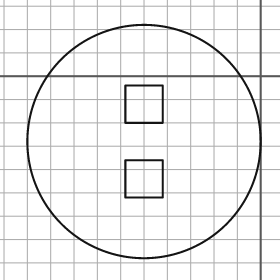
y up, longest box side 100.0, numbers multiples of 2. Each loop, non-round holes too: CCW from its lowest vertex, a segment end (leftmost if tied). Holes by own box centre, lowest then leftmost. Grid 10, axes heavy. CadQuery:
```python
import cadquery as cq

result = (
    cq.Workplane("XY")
    .moveTo(-50.0, -28.0)
    .circle(50.0)
    .moveTo(-58.0, -52.0)
    .lineTo(-42.0, -52.0)
    .lineTo(-42.0, -36.0)
    .lineTo(-58.0, -36.0)
    .close()
    .moveTo(-58.0, -20.0)
    .lineTo(-42.0, -20.0)
    .lineTo(-42.0, -4.0)
    .lineTo(-58.0, -4.0)
    .close()
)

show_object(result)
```